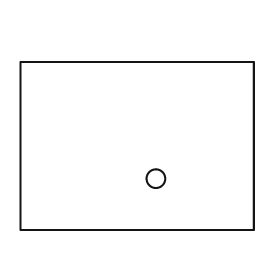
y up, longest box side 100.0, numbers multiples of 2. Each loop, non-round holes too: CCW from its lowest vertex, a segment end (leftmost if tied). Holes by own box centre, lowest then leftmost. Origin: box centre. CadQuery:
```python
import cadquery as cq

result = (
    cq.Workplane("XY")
    .moveTo(-50.0, -36.0)
    .lineTo(50.0, -36.0)
    .lineTo(50.0, 36.0)
    .lineTo(-50.0, 36.0)
    .close()
    .moveTo(8.0, -14.0)
    .circle(4.0)
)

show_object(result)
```